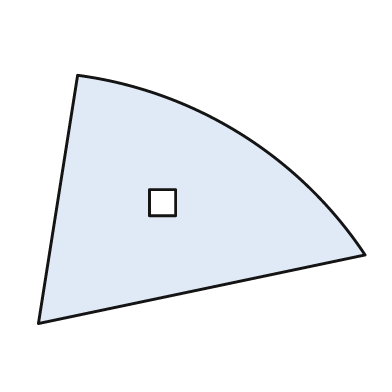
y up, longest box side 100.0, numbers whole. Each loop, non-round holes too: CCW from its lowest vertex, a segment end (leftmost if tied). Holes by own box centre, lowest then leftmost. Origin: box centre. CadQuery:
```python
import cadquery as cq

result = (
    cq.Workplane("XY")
    .moveTo(-50.0, -38.0)
    .lineTo(50.0, -17.0)
    .threePointArc((12.0, 20.0), (-38.0, 38.0))
    .close()
    .moveTo(-16.0, -5.0)
    .lineTo(-8.0, -5.0)
    .lineTo(-8.0, 3.0)
    .lineTo(-16.0, 3.0)
    .close()
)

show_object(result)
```